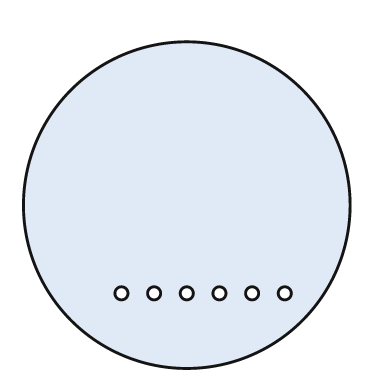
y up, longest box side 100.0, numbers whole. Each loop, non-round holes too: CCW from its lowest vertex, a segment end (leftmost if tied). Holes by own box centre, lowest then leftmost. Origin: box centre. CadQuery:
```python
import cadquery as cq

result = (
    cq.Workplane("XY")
    .moveTo(0.0, 0.0)
    .circle(50.0)
    .moveTo(-20.0, -27.0)
    .circle(2.0)
    .moveTo(-10.0, -27.0)
    .circle(2.0)
    .moveTo(0.0, -27.0)
    .circle(2.0)
    .moveTo(10.0, -27.0)
    .circle(2.0)
    .moveTo(20.0, -27.0)
    .circle(2.0)
    .moveTo(30.0, -27.0)
    .circle(2.0)
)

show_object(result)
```